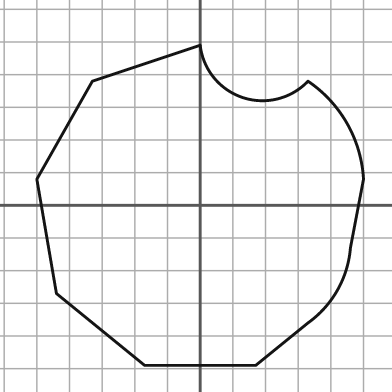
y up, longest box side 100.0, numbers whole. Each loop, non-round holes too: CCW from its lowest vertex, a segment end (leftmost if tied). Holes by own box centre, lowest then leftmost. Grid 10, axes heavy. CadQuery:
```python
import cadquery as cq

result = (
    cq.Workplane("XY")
    .moveTo(-17.0, -49.0)
    .lineTo(17.0, -49.0)
    .lineTo(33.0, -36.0)
    .threePointArc((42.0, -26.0), (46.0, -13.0))
    .lineTo(50.0, 8.0)
    .threePointArc((45.0, 25.0), (33.0, 38.0))
    .threePointArc((13.0, 33.0), (0.0, 49.0))
    .lineTo(-33.0, 38.0)
    .lineTo(-50.0, 8.0)
    .lineTo(-44.0, -27.0)
    .close()
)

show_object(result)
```